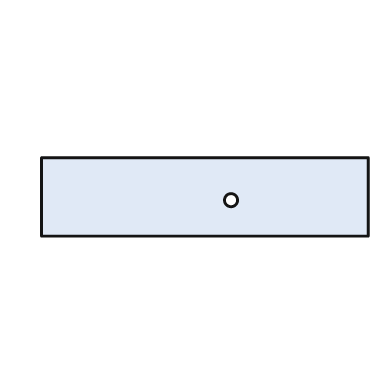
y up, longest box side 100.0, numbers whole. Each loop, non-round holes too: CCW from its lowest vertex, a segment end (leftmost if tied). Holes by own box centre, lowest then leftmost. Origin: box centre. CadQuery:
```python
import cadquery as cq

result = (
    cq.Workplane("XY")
    .moveTo(-50.0, -12.0)
    .lineTo(50.0, -12.0)
    .lineTo(50.0, 12.0)
    .lineTo(-50.0, 12.0)
    .close()
    .moveTo(8.0, -1.0)
    .circle(2.0)
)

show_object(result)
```